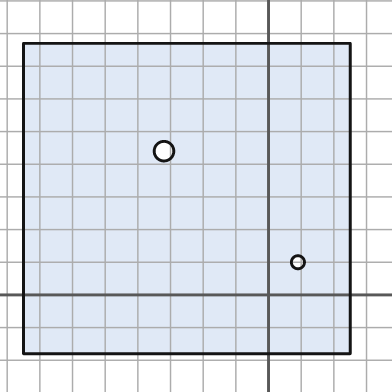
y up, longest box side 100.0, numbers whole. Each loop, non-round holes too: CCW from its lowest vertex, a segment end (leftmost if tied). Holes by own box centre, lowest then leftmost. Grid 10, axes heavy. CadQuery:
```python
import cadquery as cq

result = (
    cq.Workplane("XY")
    .moveTo(-75.0, -18.0)
    .lineTo(25.0, -18.0)
    .lineTo(25.0, 77.0)
    .lineTo(-75.0, 77.0)
    .close()
    .moveTo(9.0, 10.0)
    .circle(2.0)
    .moveTo(-32.0, 44.0)
    .circle(3.0)
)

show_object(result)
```